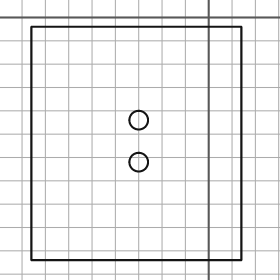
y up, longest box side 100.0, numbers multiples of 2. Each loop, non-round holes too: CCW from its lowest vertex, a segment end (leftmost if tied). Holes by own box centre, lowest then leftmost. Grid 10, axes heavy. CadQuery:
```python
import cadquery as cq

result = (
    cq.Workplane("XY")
    .moveTo(-76.0, -104.0)
    .lineTo(14.0, -104.0)
    .lineTo(14.0, -4.0)
    .lineTo(-76.0, -4.0)
    .close()
    .moveTo(-30.0, -62.0)
    .circle(4.0)
    .moveTo(-30.0, -44.0)
    .circle(4.0)
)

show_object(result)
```